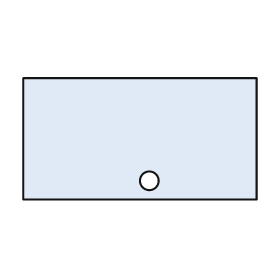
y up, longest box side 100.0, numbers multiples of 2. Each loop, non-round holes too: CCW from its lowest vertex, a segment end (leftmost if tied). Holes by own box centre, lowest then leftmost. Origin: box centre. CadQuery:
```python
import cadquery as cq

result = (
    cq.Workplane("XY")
    .moveTo(-50.0, -26.0)
    .lineTo(50.0, -26.0)
    .lineTo(50.0, 26.0)
    .lineTo(-50.0, 26.0)
    .close()
    .moveTo(4.0, -18.0)
    .circle(4.0)
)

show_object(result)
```